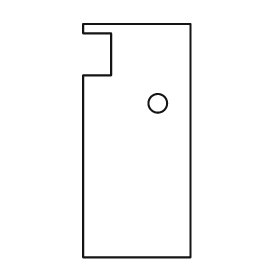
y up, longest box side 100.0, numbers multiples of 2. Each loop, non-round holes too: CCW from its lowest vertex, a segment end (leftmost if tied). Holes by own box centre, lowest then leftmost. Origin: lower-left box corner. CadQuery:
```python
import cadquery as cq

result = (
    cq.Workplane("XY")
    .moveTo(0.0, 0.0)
    .lineTo(46.0, 0.0)
    .lineTo(46.0, 100.0)
    .lineTo(0.0, 100.0)
    .lineTo(0.0, 96.0)
    .lineTo(12.0, 96.0)
    .lineTo(12.0, 78.0)
    .lineTo(0.0, 78.0)
    .close()
    .moveTo(32.0, 66.0)
    .circle(4.0)
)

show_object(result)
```